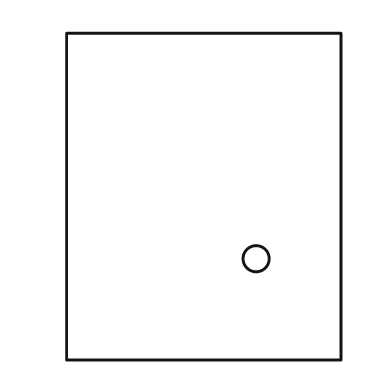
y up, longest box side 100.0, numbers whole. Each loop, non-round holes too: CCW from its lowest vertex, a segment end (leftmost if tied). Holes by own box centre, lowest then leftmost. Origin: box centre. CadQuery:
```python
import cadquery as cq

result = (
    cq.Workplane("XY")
    .moveTo(-42.0, -50.0)
    .lineTo(42.0, -50.0)
    .lineTo(42.0, 50.0)
    .lineTo(-42.0, 50.0)
    .close()
    .moveTo(16.0, -19.0)
    .circle(4.0)
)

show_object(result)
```